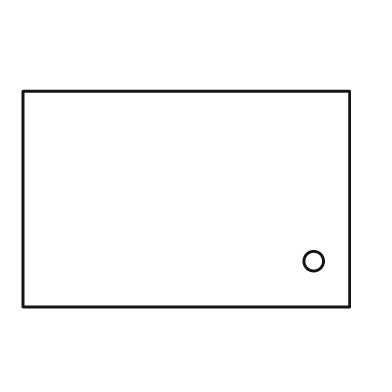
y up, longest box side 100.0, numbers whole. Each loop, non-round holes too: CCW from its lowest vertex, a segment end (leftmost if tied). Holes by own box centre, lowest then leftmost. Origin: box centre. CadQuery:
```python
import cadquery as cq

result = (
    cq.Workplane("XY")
    .moveTo(-50.0, -33.0)
    .lineTo(50.0, -33.0)
    .lineTo(50.0, 33.0)
    .lineTo(-50.0, 33.0)
    .close()
    .moveTo(39.0, -19.0)
    .circle(3.0)
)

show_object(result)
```